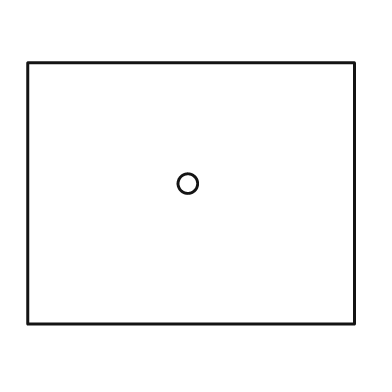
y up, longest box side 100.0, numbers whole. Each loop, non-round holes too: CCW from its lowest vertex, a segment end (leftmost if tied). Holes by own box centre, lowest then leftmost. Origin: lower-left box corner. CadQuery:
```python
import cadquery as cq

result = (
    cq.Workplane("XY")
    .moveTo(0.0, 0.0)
    .lineTo(100.0, 0.0)
    .lineTo(100.0, 80.0)
    .lineTo(0.0, 80.0)
    .close()
    .moveTo(49.0, 43.0)
    .circle(3.0)
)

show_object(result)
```